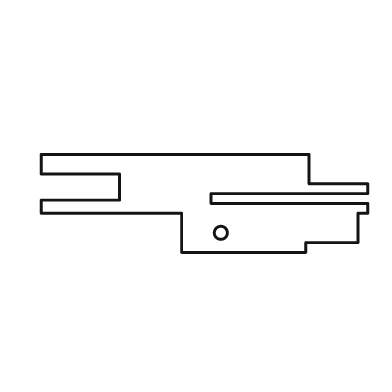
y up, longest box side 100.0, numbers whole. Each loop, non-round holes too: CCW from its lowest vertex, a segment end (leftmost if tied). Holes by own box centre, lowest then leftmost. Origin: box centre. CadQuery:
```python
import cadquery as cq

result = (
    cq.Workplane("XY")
    .moveTo(-7.0, -15.0)
    .lineTo(31.0, -15.0)
    .lineTo(31.0, -12.0)
    .lineTo(47.0, -12.0)
    .lineTo(47.0, -3.0)
    .lineTo(50.0, -3.0)
    .lineTo(50.0, 0.0)
    .lineTo(2.0, 0.0)
    .lineTo(2.0, 3.0)
    .lineTo(50.0, 3.0)
    .lineTo(50.0, 6.0)
    .lineTo(32.0, 6.0)
    .lineTo(32.0, 15.0)
    .lineTo(-50.0, 15.0)
    .lineTo(-50.0, 9.0)
    .lineTo(-26.0, 9.0)
    .lineTo(-26.0, 1.0)
    .lineTo(-50.0, 1.0)
    .lineTo(-50.0, -3.0)
    .lineTo(-7.0, -3.0)
    .close()
    .moveTo(5.0, -9.0)
    .circle(2.0)
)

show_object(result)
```